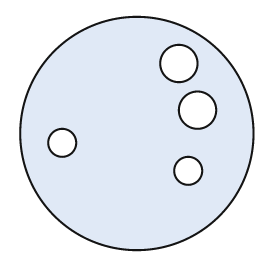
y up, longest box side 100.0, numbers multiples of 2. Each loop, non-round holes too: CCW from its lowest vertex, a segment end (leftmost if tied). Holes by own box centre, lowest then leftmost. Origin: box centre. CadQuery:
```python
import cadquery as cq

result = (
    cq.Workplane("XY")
    .moveTo(0.0, 0.0)
    .circle(50.0)
    .moveTo(22.0, -16.0)
    .circle(6.0)
    .moveTo(-32.0, -4.0)
    .circle(6.0)
    .moveTo(26.0, 10.0)
    .circle(8.0)
    .moveTo(18.0, 30.0)
    .circle(8.0)
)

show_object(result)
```